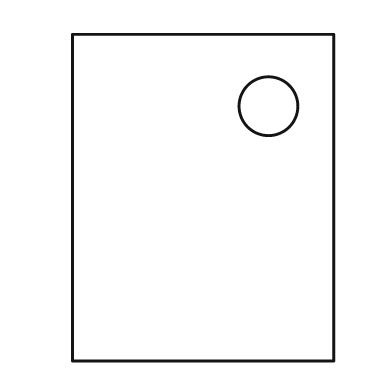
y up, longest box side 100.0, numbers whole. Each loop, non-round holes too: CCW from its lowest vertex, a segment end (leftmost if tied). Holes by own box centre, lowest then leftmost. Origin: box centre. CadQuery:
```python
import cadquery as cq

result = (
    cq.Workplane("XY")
    .moveTo(-40.0, -50.0)
    .lineTo(40.0, -50.0)
    .lineTo(40.0, 50.0)
    .lineTo(-40.0, 50.0)
    .close()
    .moveTo(20.0, 28.0)
    .circle(9.0)
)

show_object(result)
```